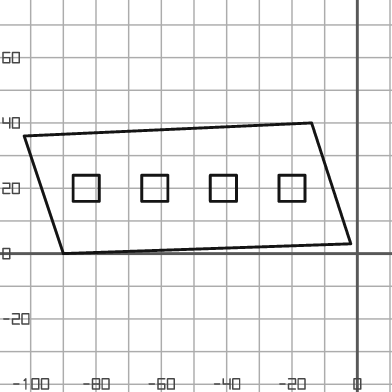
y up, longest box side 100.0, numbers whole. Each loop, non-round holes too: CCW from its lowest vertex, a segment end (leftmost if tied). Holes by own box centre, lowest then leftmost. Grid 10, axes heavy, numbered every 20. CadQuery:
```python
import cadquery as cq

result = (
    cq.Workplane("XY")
    .moveTo(-90.0, 0.0)
    .lineTo(-2.0, 3.0)
    .lineTo(-14.0, 40.0)
    .lineTo(-102.0, 36.0)
    .close()
    .moveTo(-87.0, 16.0)
    .lineTo(-79.0, 16.0)
    .lineTo(-79.0, 24.0)
    .lineTo(-87.0, 24.0)
    .close()
    .moveTo(-66.0, 16.0)
    .lineTo(-58.0, 16.0)
    .lineTo(-58.0, 24.0)
    .lineTo(-66.0, 24.0)
    .close()
    .moveTo(-45.0, 16.0)
    .lineTo(-37.0, 16.0)
    .lineTo(-37.0, 24.0)
    .lineTo(-45.0, 24.0)
    .close()
    .moveTo(-24.0, 16.0)
    .lineTo(-16.0, 16.0)
    .lineTo(-16.0, 24.0)
    .lineTo(-24.0, 24.0)
    .close()
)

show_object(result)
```